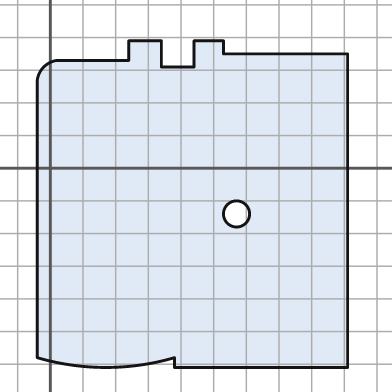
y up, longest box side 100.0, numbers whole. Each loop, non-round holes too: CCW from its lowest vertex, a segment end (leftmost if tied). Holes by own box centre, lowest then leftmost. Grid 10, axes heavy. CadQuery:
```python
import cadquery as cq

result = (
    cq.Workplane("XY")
    .moveTo(38.0, -61.0)
    .lineTo(91.0, -61.0)
    .lineTo(91.0, 35.0)
    .lineTo(53.0, 35.0)
    .lineTo(53.0, 39.0)
    .lineTo(44.0, 39.0)
    .lineTo(44.0, 31.0)
    .lineTo(34.0, 31.0)
    .lineTo(34.0, 39.0)
    .lineTo(24.0, 39.0)
    .lineTo(24.0, 33.0)
    .lineTo(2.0, 33.0)
    .threePointArc((-2.0, 31.0), (-4.0, 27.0))
    .lineTo(-4.0, -58.0)
    .threePointArc((17.0, -61.0), (38.0, -58.0))
    .close()
    .moveTo(57.0, -14.0)
    .circle(4.0)
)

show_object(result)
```